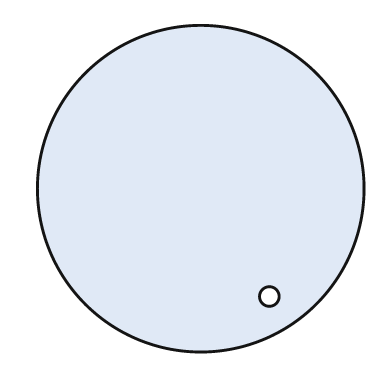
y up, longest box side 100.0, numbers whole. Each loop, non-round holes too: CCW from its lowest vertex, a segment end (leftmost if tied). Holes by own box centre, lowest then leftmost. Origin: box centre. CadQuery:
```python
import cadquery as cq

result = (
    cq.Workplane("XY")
    .moveTo(0.0, 0.0)
    .circle(50.0)
    .moveTo(21.0, -33.0)
    .circle(3.0)
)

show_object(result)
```